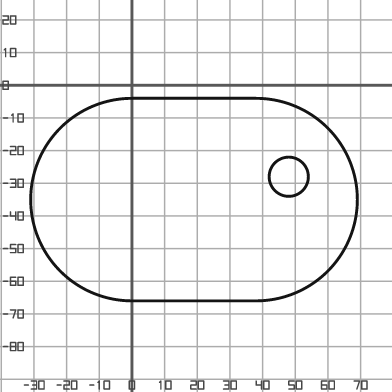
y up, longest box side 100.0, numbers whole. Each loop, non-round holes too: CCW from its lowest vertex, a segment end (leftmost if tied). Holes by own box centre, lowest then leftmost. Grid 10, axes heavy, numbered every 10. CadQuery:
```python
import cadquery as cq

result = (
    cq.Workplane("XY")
    .moveTo(0.0, -66.0)
    .lineTo(38.0, -66.0)
    .threePointArc((69.0, -35.0), (38.0, -4.0))
    .lineTo(0.0, -4.0)
    .threePointArc((-31.0, -35.0), (0.0, -66.0))
    .close()
    .moveTo(48.0, -28.0)
    .circle(6.0)
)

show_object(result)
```